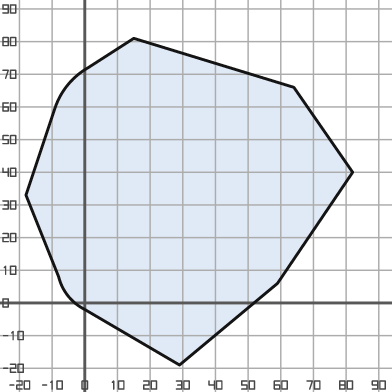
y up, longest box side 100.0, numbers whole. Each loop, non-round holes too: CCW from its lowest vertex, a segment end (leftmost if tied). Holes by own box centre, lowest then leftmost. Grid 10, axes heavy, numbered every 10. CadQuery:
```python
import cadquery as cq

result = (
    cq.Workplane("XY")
    .moveTo(29.0, -19.0)
    .lineTo(59.0, 6.0)
    .lineTo(82.0, 40.0)
    .lineTo(64.0, 66.0)
    .lineTo(15.0, 81.0)
    .lineTo(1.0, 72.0)
    .threePointArc((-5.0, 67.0), (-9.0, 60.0))
    .lineTo(-18.0, 33.0)
    .lineTo(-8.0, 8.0)
    .threePointArc((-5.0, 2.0), (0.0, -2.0))
    .close()
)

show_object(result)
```